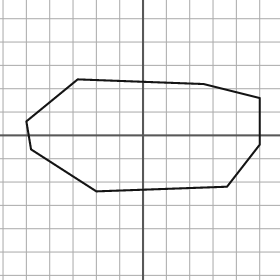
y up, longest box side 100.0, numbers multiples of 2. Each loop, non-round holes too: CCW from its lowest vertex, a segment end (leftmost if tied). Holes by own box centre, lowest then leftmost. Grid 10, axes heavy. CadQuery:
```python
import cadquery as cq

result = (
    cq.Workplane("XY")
    .moveTo(-20.0, -24.0)
    .lineTo(36.0, -22.0)
    .lineTo(50.0, -4.0)
    .lineTo(50.0, 16.0)
    .lineTo(26.0, 22.0)
    .lineTo(-28.0, 24.0)
    .lineTo(-50.0, 6.0)
    .lineTo(-48.0, -6.0)
    .close()
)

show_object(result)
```